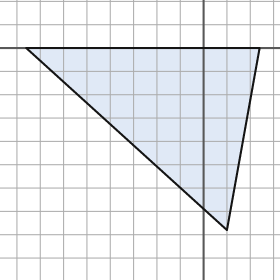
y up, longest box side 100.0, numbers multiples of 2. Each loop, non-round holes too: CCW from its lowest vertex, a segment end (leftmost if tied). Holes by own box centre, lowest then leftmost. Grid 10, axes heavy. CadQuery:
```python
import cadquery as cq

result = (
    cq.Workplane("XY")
    .moveTo(10.0, -78.0)
    .lineTo(24.0, 0.0)
    .lineTo(-76.0, 0.0)
    .close()
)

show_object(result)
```